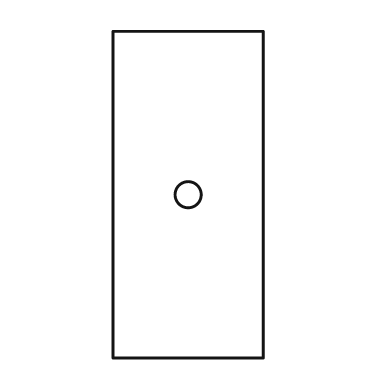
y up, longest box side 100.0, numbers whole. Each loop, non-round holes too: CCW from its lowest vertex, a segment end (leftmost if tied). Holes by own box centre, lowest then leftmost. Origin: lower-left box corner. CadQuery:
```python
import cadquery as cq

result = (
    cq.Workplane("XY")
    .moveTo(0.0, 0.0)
    .lineTo(46.0, 0.0)
    .lineTo(46.0, 100.0)
    .lineTo(0.0, 100.0)
    .close()
    .moveTo(23.0, 50.0)
    .circle(4.0)
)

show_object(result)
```